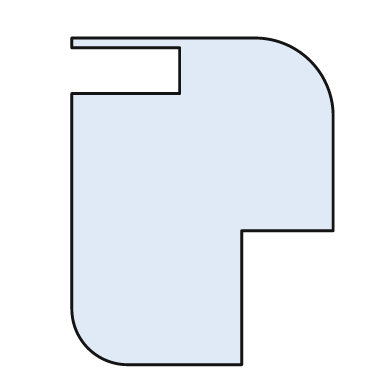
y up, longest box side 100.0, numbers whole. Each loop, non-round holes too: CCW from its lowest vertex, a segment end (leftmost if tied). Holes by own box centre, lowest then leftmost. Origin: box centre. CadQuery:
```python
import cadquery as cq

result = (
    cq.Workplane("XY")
    .moveTo(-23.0, -50.0)
    .lineTo(12.0, -50.0)
    .lineTo(12.0, -9.0)
    .lineTo(40.0, -9.0)
    .lineTo(40.0, 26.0)
    .threePointArc((33.0, 43.0), (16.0, 50.0))
    .lineTo(-40.0, 50.0)
    .lineTo(-40.0, 47.0)
    .lineTo(-7.0, 47.0)
    .lineTo(-7.0, 33.0)
    .lineTo(-40.0, 33.0)
    .lineTo(-40.0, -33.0)
    .threePointArc((-35.0, -45.0), (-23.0, -50.0))
    .close()
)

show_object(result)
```